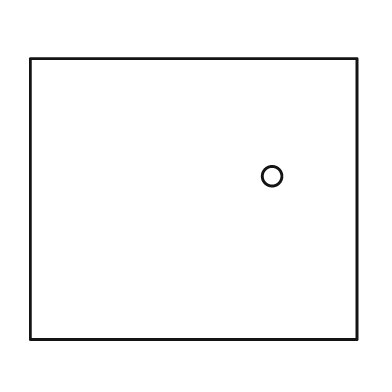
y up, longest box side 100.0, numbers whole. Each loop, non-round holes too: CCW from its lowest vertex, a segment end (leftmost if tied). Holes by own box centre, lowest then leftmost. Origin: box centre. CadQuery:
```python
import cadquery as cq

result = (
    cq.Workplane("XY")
    .moveTo(-50.0, -43.0)
    .lineTo(50.0, -43.0)
    .lineTo(50.0, 43.0)
    .lineTo(-50.0, 43.0)
    .close()
    .moveTo(24.0, 7.0)
    .circle(3.0)
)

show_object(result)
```